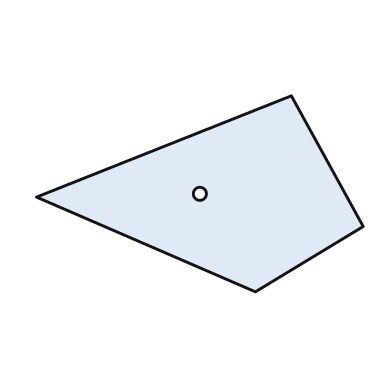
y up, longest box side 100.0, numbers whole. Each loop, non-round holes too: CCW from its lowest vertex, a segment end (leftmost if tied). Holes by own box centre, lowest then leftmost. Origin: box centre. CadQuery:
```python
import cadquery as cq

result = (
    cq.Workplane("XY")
    .moveTo(17.0, -30.0)
    .lineTo(50.0, -10.0)
    .lineTo(28.0, 30.0)
    .lineTo(-50.0, -1.0)
    .close()
    .moveTo(0.0, 0.0)
    .circle(2.0)
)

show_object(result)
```